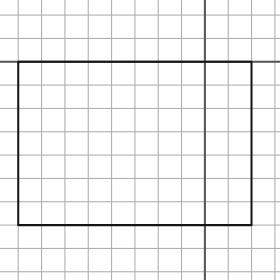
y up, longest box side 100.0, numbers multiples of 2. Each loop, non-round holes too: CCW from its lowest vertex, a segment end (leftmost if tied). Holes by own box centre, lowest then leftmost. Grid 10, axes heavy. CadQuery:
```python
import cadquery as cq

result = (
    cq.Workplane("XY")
    .moveTo(-80.0, -70.0)
    .lineTo(20.0, -70.0)
    .lineTo(20.0, 0.0)
    .lineTo(-80.0, 0.0)
    .close()
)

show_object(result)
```